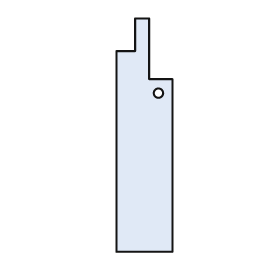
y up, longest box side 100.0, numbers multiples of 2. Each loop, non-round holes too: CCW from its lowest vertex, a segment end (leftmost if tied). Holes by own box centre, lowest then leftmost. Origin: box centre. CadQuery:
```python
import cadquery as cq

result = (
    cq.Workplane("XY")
    .moveTo(-12.0, -50.0)
    .lineTo(12.0, -50.0)
    .lineTo(12.0, 24.0)
    .lineTo(2.0, 24.0)
    .lineTo(2.0, 50.0)
    .lineTo(-4.0, 50.0)
    .lineTo(-4.0, 36.0)
    .lineTo(-12.0, 36.0)
    .close()
    .moveTo(6.0, 18.0)
    .circle(2.0)
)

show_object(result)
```